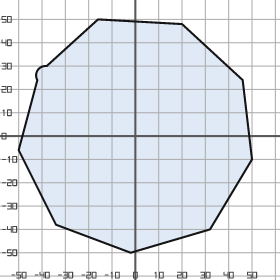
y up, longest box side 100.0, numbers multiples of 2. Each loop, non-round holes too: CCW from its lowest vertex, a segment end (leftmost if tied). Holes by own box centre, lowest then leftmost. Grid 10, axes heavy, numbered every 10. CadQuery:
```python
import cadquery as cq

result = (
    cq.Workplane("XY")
    .moveTo(-2.0, -50.0)
    .lineTo(32.0, -40.0)
    .lineTo(50.0, -10.0)
    .lineTo(46.0, 24.0)
    .lineTo(20.0, 48.0)
    .lineTo(-16.0, 50.0)
    .lineTo(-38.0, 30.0)
    .threePointArc((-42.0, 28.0), (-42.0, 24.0))
    .lineTo(-50.0, -6.0)
    .lineTo(-34.0, -38.0)
    .close()
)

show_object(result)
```